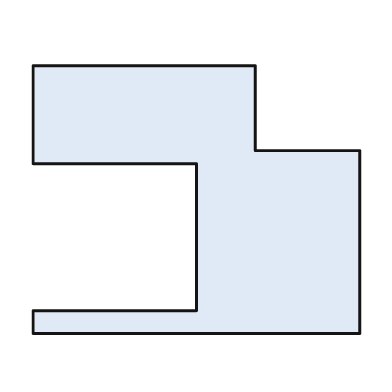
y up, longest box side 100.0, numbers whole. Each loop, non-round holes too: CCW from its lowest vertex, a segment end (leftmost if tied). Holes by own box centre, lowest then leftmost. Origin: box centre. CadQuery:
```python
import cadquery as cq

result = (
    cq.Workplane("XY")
    .moveTo(-50.0, -41.0)
    .lineTo(50.0, -41.0)
    .lineTo(50.0, 15.0)
    .lineTo(18.0, 15.0)
    .lineTo(18.0, 41.0)
    .lineTo(-50.0, 41.0)
    .lineTo(-50.0, 11.0)
    .lineTo(0.0, 11.0)
    .lineTo(0.0, -34.0)
    .lineTo(-50.0, -34.0)
    .close()
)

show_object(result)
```